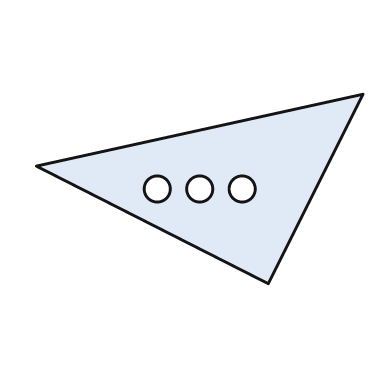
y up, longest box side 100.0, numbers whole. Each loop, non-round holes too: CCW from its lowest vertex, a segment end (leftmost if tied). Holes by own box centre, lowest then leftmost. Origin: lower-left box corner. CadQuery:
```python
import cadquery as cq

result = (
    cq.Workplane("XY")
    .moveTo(71.0, 0.0)
    .lineTo(100.0, 58.0)
    .lineTo(0.0, 36.0)
    .close()
    .moveTo(37.0, 29.0)
    .circle(4.0)
    .moveTo(50.0, 29.0)
    .circle(4.0)
    .moveTo(63.0, 29.0)
    .circle(4.0)
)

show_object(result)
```